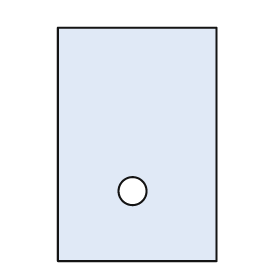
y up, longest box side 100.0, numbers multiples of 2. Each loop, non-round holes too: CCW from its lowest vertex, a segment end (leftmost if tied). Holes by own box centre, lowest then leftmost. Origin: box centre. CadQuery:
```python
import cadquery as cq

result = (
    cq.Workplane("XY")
    .moveTo(-34.0, -50.0)
    .lineTo(34.0, -50.0)
    .lineTo(34.0, 50.0)
    .lineTo(-34.0, 50.0)
    .close()
    .moveTo(-2.0, -20.0)
    .circle(6.0)
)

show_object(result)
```